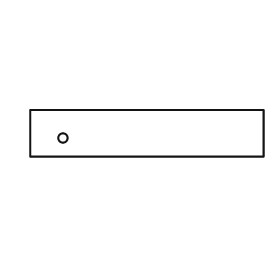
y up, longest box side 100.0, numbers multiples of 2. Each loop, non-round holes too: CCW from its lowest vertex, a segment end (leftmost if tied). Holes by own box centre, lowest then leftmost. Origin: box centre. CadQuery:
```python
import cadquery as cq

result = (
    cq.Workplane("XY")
    .moveTo(-50.0, -10.0)
    .lineTo(50.0, -10.0)
    .lineTo(50.0, 10.0)
    .lineTo(-50.0, 10.0)
    .close()
    .moveTo(-36.0, -2.0)
    .circle(2.0)
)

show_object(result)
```